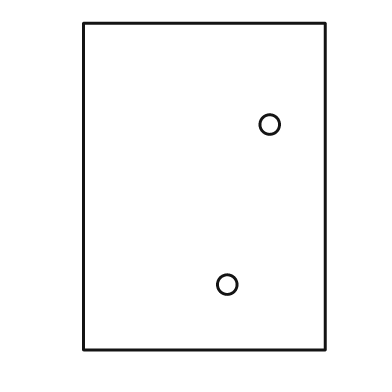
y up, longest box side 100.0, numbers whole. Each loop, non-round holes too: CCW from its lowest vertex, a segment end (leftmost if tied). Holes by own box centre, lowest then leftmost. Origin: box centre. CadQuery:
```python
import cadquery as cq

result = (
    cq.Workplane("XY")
    .moveTo(-37.0, -50.0)
    .lineTo(37.0, -50.0)
    .lineTo(37.0, 50.0)
    .lineTo(-37.0, 50.0)
    .close()
    .moveTo(7.0, -30.0)
    .circle(3.0)
    .moveTo(20.0, 19.0)
    .circle(3.0)
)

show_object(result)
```